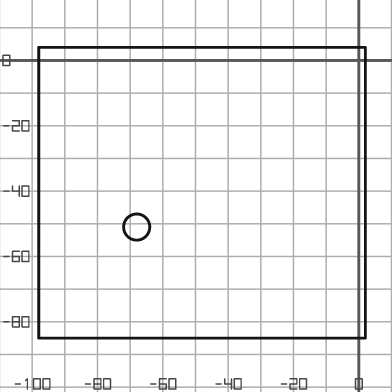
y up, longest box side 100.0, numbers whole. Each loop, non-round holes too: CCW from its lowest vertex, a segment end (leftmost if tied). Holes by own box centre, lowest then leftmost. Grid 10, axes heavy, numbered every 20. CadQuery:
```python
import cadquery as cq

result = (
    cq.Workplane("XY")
    .moveTo(-98.0, -85.0)
    .lineTo(2.0, -85.0)
    .lineTo(2.0, 4.0)
    .lineTo(-98.0, 4.0)
    .close()
    .moveTo(-68.0, -51.0)
    .circle(4.0)
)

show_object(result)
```